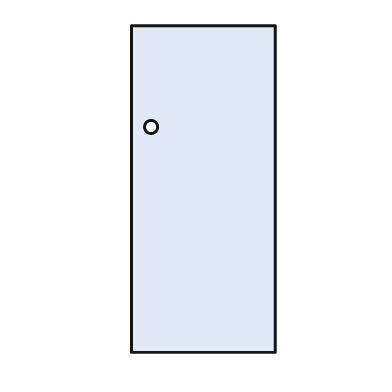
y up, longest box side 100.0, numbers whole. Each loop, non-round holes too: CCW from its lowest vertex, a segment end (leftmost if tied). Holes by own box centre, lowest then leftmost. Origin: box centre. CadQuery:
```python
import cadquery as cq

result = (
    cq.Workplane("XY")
    .moveTo(-22.0, -50.0)
    .lineTo(22.0, -50.0)
    .lineTo(22.0, 50.0)
    .lineTo(-22.0, 50.0)
    .close()
    .moveTo(-16.0, 19.0)
    .circle(2.0)
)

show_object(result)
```